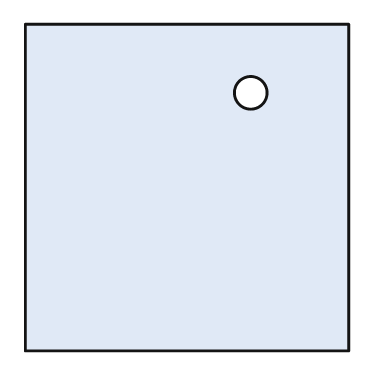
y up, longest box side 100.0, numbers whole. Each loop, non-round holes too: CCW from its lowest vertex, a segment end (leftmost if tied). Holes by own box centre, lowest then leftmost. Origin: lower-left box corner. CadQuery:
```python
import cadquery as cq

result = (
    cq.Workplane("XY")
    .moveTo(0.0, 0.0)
    .lineTo(99.0, 0.0)
    .lineTo(99.0, 100.0)
    .lineTo(0.0, 100.0)
    .close()
    .moveTo(69.0, 79.0)
    .circle(5.0)
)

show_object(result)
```